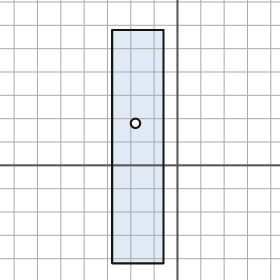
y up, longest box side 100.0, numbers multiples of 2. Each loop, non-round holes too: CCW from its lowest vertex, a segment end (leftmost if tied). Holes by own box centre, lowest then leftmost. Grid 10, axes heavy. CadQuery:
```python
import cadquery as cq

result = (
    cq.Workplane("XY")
    .moveTo(-28.0, -42.0)
    .lineTo(-6.0, -42.0)
    .lineTo(-6.0, 58.0)
    .lineTo(-28.0, 58.0)
    .close()
    .moveTo(-18.0, 18.0)
    .circle(2.0)
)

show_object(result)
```